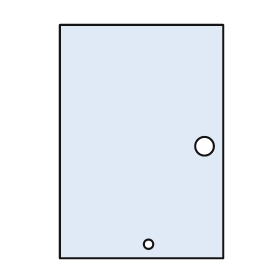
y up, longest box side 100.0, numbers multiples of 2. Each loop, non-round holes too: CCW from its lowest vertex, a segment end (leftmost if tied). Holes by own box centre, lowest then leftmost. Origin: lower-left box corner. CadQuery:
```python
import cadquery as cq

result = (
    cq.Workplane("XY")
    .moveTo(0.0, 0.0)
    .lineTo(70.0, 0.0)
    .lineTo(70.0, 100.0)
    .lineTo(0.0, 100.0)
    .close()
    .moveTo(38.0, 6.0)
    .circle(2.0)
    .moveTo(62.0, 48.0)
    .circle(4.0)
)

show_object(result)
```